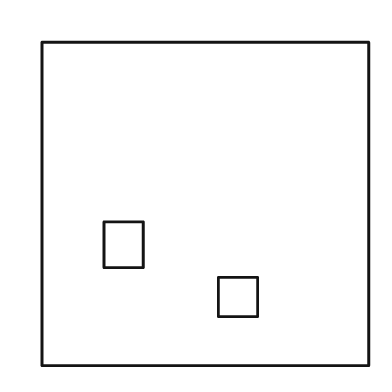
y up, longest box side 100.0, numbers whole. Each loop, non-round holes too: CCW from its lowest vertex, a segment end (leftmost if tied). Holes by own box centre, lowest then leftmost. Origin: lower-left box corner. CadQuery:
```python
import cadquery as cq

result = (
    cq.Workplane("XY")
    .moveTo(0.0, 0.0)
    .lineTo(100.0, 0.0)
    .lineTo(100.0, 99.0)
    .lineTo(0.0, 99.0)
    .close()
    .moveTo(54.0, 15.0)
    .lineTo(66.0, 15.0)
    .lineTo(66.0, 27.0)
    .lineTo(54.0, 27.0)
    .close()
    .moveTo(19.0, 30.0)
    .lineTo(31.0, 30.0)
    .lineTo(31.0, 44.0)
    .lineTo(19.0, 44.0)
    .close()
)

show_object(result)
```